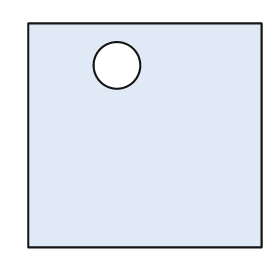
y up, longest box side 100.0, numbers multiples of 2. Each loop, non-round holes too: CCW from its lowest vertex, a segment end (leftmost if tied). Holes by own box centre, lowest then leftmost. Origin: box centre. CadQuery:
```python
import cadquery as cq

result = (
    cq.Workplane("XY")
    .moveTo(-50.0, -48.0)
    .lineTo(50.0, -48.0)
    .lineTo(50.0, 48.0)
    .lineTo(-50.0, 48.0)
    .close()
    .moveTo(-12.0, 30.0)
    .circle(10.0)
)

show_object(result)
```